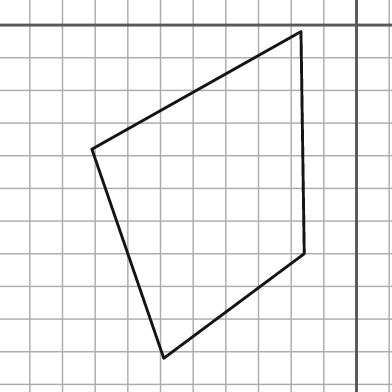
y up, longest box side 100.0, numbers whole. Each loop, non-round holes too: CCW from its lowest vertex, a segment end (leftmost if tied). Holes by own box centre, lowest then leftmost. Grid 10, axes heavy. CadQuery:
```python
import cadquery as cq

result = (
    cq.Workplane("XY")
    .moveTo(-59.0, -102.0)
    .lineTo(-16.0, -70.0)
    .lineTo(-17.0, -2.0)
    .lineTo(-81.0, -38.0)
    .close()
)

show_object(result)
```